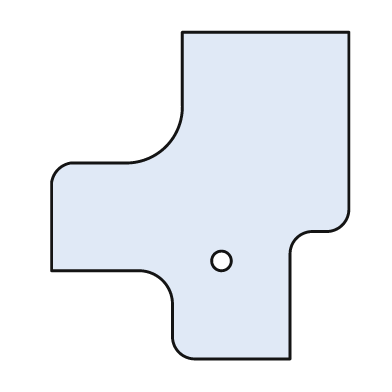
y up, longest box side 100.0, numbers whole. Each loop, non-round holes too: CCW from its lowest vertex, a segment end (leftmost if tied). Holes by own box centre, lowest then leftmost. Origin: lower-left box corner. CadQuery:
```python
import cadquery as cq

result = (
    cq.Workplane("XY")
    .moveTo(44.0, 0.0)
    .lineTo(73.0, 0.0)
    .lineTo(73.0, 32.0)
    .threePointArc((75.0, 37.0), (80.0, 39.0))
    .lineTo(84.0, 39.0)
    .threePointArc((89.0, 41.0), (91.0, 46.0))
    .lineTo(91.0, 100.0)
    .lineTo(40.0, 100.0)
    .lineTo(40.0, 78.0)
    .threePointArc((35.0, 65.0), (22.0, 60.0))
    .lineTo(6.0, 60.0)
    .threePointArc((2.0, 58.0), (0.0, 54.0))
    .lineTo(0.0, 27.0)
    .lineTo(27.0, 27.0)
    .threePointArc((34.0, 24.0), (37.0, 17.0))
    .lineTo(37.0, 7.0)
    .threePointArc((39.0, 2.0), (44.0, 0.0))
    .close()
    .moveTo(52.0, 30.0)
    .circle(3.0)
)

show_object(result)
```